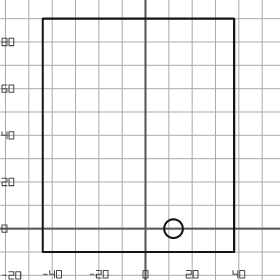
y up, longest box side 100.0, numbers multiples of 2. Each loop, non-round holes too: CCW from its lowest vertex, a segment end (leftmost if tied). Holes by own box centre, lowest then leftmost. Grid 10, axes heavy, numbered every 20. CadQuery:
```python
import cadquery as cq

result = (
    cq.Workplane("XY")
    .moveTo(-44.0, -10.0)
    .lineTo(38.0, -10.0)
    .lineTo(38.0, 90.0)
    .lineTo(-44.0, 90.0)
    .close()
    .moveTo(12.0, 0.0)
    .circle(4.0)
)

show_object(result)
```